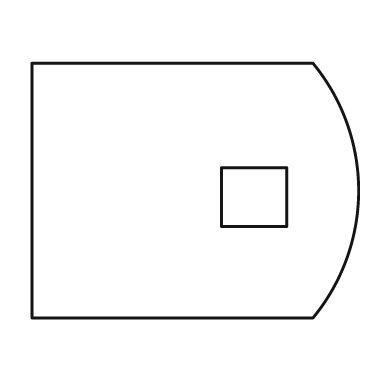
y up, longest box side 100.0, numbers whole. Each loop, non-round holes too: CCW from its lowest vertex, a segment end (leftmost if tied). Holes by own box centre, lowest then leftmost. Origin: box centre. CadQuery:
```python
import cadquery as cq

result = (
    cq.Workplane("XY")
    .moveTo(-50.0, -39.0)
    .lineTo(36.0, -39.0)
    .threePointArc((50.0, 0.0), (36.0, 39.0))
    .lineTo(-50.0, 39.0)
    .close()
    .moveTo(8.0, -11.0)
    .lineTo(28.0, -11.0)
    .lineTo(28.0, 7.0)
    .lineTo(8.0, 7.0)
    .close()
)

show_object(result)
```